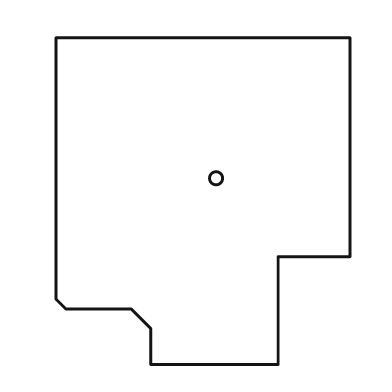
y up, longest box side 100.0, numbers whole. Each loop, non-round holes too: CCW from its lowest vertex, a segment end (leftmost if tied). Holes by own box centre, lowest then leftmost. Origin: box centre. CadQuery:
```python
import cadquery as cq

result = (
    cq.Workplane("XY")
    .moveTo(-16.0, -50.0)
    .lineTo(23.0, -50.0)
    .lineTo(23.0, -17.0)
    .lineTo(45.0, -17.0)
    .lineTo(45.0, 50.0)
    .lineTo(-45.0, 50.0)
    .lineTo(-45.0, -30.0)
    .lineTo(-42.0, -33.0)
    .lineTo(-22.0, -33.0)
    .lineTo(-16.0, -39.0)
    .close()
    .moveTo(4.0, 7.0)
    .circle(2.0)
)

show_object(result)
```